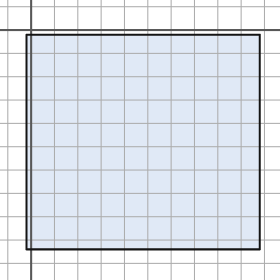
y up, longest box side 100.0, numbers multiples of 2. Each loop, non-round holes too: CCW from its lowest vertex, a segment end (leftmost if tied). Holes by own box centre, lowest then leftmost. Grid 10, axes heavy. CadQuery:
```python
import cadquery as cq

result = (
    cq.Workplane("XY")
    .moveTo(-2.0, -94.0)
    .lineTo(98.0, -94.0)
    .lineTo(98.0, -2.0)
    .lineTo(-2.0, -2.0)
    .close()
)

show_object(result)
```